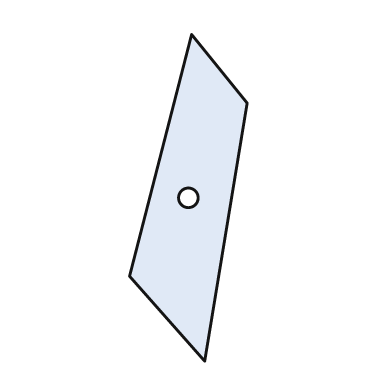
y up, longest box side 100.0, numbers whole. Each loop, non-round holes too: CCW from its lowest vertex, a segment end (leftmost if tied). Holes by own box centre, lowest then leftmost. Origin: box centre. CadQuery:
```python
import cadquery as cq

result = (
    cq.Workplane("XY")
    .moveTo(5.0, -50.0)
    .lineTo(18.0, 29.0)
    .lineTo(1.0, 50.0)
    .lineTo(-18.0, -24.0)
    .close()
    .moveTo(0.0, 0.0)
    .circle(3.0)
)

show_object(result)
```